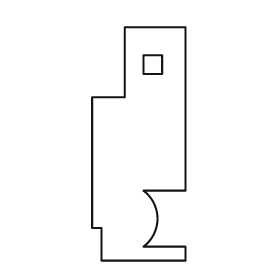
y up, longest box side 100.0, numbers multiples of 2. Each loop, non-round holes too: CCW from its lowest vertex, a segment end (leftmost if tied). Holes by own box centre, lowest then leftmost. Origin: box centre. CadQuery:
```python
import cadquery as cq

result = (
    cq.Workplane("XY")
    .moveTo(-16.0, -50.0)
    .lineTo(20.0, -50.0)
    .lineTo(20.0, -44.0)
    .lineTo(2.0, -44.0)
    .threePointArc((8.0, -32.0), (2.0, -20.0))
    .lineTo(20.0, -20.0)
    .lineTo(20.0, 50.0)
    .lineTo(-6.0, 50.0)
    .lineTo(-6.0, 20.0)
    .lineTo(-20.0, 20.0)
    .lineTo(-20.0, -36.0)
    .lineTo(-16.0, -36.0)
    .close()
    .moveTo(2.0, 30.0)
    .lineTo(10.0, 30.0)
    .lineTo(10.0, 38.0)
    .lineTo(2.0, 38.0)
    .close()
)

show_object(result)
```